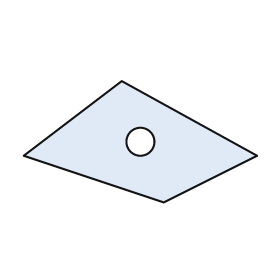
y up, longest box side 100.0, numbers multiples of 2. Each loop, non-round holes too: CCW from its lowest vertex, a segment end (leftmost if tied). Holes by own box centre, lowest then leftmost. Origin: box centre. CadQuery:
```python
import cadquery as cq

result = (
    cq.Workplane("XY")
    .moveTo(10.0, -26.0)
    .lineTo(50.0, -6.0)
    .lineTo(-8.0, 26.0)
    .lineTo(-50.0, -6.0)
    .close()
    .moveTo(0.0, 0.0)
    .circle(6.0)
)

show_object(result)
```